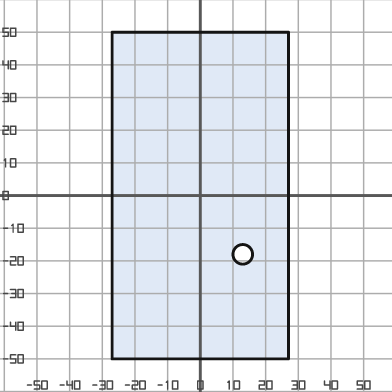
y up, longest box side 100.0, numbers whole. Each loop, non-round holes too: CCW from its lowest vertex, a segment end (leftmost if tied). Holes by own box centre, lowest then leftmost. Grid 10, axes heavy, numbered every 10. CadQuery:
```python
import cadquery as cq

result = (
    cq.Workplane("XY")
    .moveTo(-27.0, -50.0)
    .lineTo(27.0, -50.0)
    .lineTo(27.0, 50.0)
    .lineTo(-27.0, 50.0)
    .close()
    .moveTo(13.0, -18.0)
    .circle(3.0)
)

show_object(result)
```